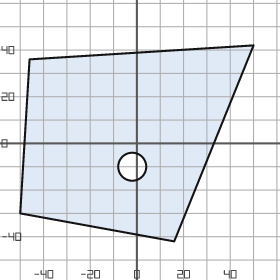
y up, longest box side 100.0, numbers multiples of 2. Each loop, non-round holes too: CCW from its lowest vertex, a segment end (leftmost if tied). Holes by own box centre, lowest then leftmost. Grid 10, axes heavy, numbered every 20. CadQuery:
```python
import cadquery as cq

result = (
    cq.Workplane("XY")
    .moveTo(16.0, -42.0)
    .lineTo(50.0, 42.0)
    .lineTo(-46.0, 36.0)
    .lineTo(-50.0, -30.0)
    .close()
    .moveTo(-2.0, -10.0)
    .circle(6.0)
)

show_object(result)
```